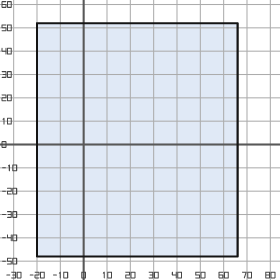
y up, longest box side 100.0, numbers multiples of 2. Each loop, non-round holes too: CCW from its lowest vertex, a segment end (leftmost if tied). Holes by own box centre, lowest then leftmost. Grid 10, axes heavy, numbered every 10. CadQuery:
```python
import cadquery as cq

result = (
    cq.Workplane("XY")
    .moveTo(-20.0, -48.0)
    .lineTo(66.0, -48.0)
    .lineTo(66.0, 52.0)
    .lineTo(-20.0, 52.0)
    .close()
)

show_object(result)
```